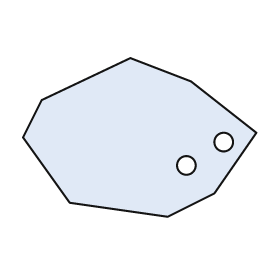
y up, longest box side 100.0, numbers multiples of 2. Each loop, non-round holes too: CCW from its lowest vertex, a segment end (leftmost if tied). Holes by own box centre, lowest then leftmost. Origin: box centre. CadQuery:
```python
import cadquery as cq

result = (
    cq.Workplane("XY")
    .moveTo(12.0, -34.0)
    .lineTo(32.0, -24.0)
    .lineTo(50.0, 2.0)
    .lineTo(22.0, 24.0)
    .lineTo(-4.0, 34.0)
    .lineTo(-42.0, 16.0)
    .lineTo(-50.0, 0.0)
    .lineTo(-30.0, -28.0)
    .close()
    .moveTo(20.0, -12.0)
    .circle(4.0)
    .moveTo(36.0, -2.0)
    .circle(4.0)
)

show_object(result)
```